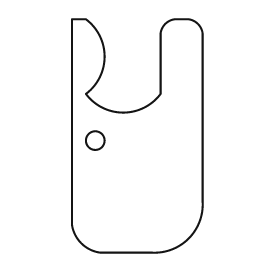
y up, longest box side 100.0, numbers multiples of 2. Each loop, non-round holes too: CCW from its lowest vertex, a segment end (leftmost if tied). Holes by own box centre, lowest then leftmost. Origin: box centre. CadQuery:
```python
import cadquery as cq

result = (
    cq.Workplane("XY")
    .moveTo(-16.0, -50.0)
    .lineTo(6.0, -50.0)
    .threePointArc((22.0, -44.0), (28.0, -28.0))
    .lineTo(28.0, 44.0)
    .threePointArc((26.0, 48.0), (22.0, 50.0))
    .lineTo(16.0, 50.0)
    .threePointArc((12.0, 48.0), (10.0, 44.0))
    .lineTo(10.0, 18.0)
    .threePointArc((-6.0, 10.0), (-22.0, 18.0))
    .threePointArc((-14.0, 34.0), (-22.0, 50.0))
    .lineTo(-28.0, 50.0)
    .lineTo(-28.0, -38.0)
    .threePointArc((-24.0, -46.0), (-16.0, -50.0))
    .close()
    .moveTo(-18.0, -2.0)
    .circle(4.0)
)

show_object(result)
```